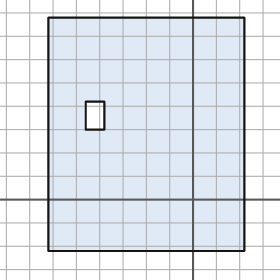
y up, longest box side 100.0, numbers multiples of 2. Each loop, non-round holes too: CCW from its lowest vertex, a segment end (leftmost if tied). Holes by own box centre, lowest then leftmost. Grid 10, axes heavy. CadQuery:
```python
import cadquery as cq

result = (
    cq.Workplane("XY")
    .moveTo(-62.0, -22.0)
    .lineTo(22.0, -22.0)
    .lineTo(22.0, 78.0)
    .lineTo(-62.0, 78.0)
    .close()
    .moveTo(-46.0, 30.0)
    .lineTo(-38.0, 30.0)
    .lineTo(-38.0, 42.0)
    .lineTo(-46.0, 42.0)
    .close()
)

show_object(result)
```